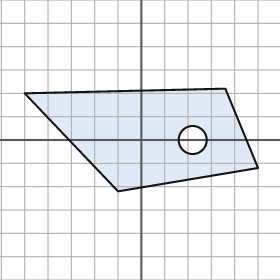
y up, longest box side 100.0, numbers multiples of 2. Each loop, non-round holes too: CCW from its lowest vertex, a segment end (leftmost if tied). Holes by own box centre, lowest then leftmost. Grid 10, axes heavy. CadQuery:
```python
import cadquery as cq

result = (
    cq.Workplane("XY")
    .moveTo(-10.0, -22.0)
    .lineTo(50.0, -12.0)
    .lineTo(36.0, 22.0)
    .lineTo(-50.0, 20.0)
    .close()
    .moveTo(22.0, 0.0)
    .circle(6.0)
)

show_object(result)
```